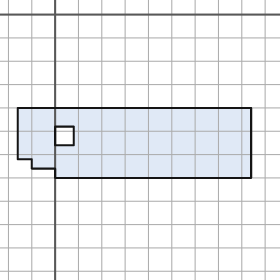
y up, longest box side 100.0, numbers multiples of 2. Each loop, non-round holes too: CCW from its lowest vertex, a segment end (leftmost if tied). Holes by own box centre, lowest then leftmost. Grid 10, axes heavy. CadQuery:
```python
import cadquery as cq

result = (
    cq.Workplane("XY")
    .moveTo(0.0, -70.0)
    .lineTo(84.0, -70.0)
    .lineTo(84.0, -40.0)
    .lineTo(-16.0, -40.0)
    .lineTo(-16.0, -62.0)
    .lineTo(-10.0, -62.0)
    .lineTo(-10.0, -66.0)
    .lineTo(0.0, -66.0)
    .close()
    .moveTo(0.0, -56.0)
    .lineTo(8.0, -56.0)
    .lineTo(8.0, -48.0)
    .lineTo(0.0, -48.0)
    .close()
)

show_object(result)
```